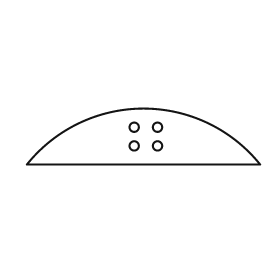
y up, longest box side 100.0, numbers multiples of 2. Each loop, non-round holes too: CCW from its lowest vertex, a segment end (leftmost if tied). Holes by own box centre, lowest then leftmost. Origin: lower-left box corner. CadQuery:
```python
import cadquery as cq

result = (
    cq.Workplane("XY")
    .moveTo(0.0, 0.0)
    .lineTo(100.0, 0.0)
    .threePointArc((50.0, 24.0), (0.0, 0.0))
    .close()
    .moveTo(46.0, 8.0)
    .circle(2.0)
    .moveTo(56.0, 8.0)
    .circle(2.0)
    .moveTo(46.0, 16.0)
    .circle(2.0)
    .moveTo(56.0, 16.0)
    .circle(2.0)
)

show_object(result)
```